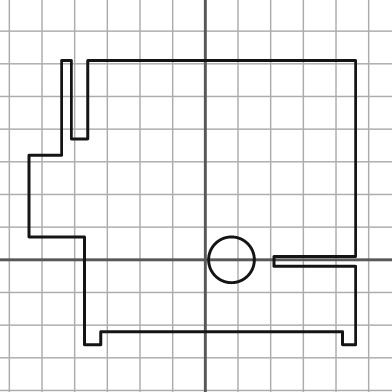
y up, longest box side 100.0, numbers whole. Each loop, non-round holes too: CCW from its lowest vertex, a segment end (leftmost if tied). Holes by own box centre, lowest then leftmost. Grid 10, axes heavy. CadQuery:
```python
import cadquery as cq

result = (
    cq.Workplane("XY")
    .moveTo(-37.0, -26.0)
    .lineTo(-32.0, -26.0)
    .lineTo(-32.0, -22.0)
    .lineTo(42.0, -22.0)
    .lineTo(42.0, -26.0)
    .lineTo(46.0, -26.0)
    .lineTo(46.0, -2.0)
    .lineTo(21.0, -2.0)
    .lineTo(21.0, 1.0)
    .lineTo(46.0, 1.0)
    .lineTo(46.0, 61.0)
    .lineTo(-36.0, 61.0)
    .lineTo(-36.0, 37.0)
    .lineTo(-41.0, 37.0)
    .lineTo(-41.0, 61.0)
    .lineTo(-44.0, 61.0)
    .lineTo(-44.0, 32.0)
    .lineTo(-54.0, 32.0)
    .lineTo(-54.0, 7.0)
    .lineTo(-37.0, 7.0)
    .close()
    .moveTo(8.0, 0.0)
    .circle(7.0)
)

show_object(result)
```